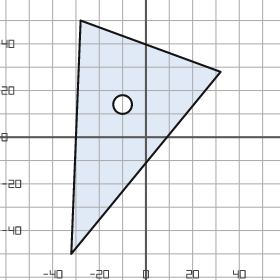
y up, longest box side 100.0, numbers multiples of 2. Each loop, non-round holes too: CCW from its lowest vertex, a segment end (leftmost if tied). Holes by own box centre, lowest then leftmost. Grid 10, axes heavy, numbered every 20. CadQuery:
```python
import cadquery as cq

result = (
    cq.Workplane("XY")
    .moveTo(-32.0, -50.0)
    .lineTo(32.0, 28.0)
    .lineTo(-28.0, 50.0)
    .close()
    .moveTo(-10.0, 14.0)
    .circle(4.0)
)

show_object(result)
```